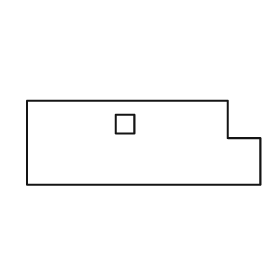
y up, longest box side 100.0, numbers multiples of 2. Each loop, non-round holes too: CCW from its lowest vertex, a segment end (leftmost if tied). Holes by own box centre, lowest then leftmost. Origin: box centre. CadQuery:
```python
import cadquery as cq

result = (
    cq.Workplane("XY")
    .moveTo(-50.0, -18.0)
    .lineTo(50.0, -18.0)
    .lineTo(50.0, 2.0)
    .lineTo(36.0, 2.0)
    .lineTo(36.0, 18.0)
    .lineTo(-50.0, 18.0)
    .close()
    .moveTo(-12.0, 4.0)
    .lineTo(-4.0, 4.0)
    .lineTo(-4.0, 12.0)
    .lineTo(-12.0, 12.0)
    .close()
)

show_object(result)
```